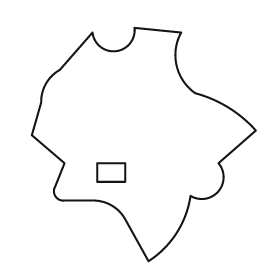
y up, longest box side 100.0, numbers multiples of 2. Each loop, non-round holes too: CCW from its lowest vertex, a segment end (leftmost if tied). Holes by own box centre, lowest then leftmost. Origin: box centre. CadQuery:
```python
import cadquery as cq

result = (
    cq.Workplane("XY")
    .moveTo(2.0, -50.0)
    .threePointArc((14.0, -38.0), (20.0, -22.0))
    .threePointArc((32.0, -20.0), (32.0, -8.0))
    .lineTo(48.0, 6.0)
    .threePointArc((36.0, 16.0), (22.0, 22.0))
    .threePointArc((14.0, 34.0), (16.0, 48.0))
    .lineTo(-4.0, 50.0)
    .threePointArc((-12.0, 40.0), (-22.0, 48.0))
    .lineTo(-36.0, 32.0)
    .threePointArc((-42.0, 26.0), (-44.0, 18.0))
    .lineTo(-48.0, 4.0)
    .lineTo(-34.0, -8.0)
    .lineTo(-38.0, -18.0)
    .threePointArc((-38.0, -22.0), (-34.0, -24.0))
    .lineTo(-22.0, -24.0)
    .threePointArc((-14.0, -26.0), (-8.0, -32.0))
    .close()
    .moveTo(-20.0, -16.0)
    .lineTo(-8.0, -16.0)
    .lineTo(-8.0, -8.0)
    .lineTo(-20.0, -8.0)
    .close()
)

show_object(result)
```